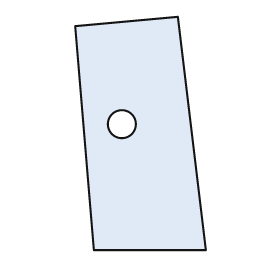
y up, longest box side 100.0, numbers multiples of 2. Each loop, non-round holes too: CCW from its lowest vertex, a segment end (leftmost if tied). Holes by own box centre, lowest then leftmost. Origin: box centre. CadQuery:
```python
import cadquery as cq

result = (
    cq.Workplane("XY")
    .moveTo(-20.0, -50.0)
    .lineTo(28.0, -50.0)
    .lineTo(16.0, 50.0)
    .lineTo(-28.0, 46.0)
    .close()
    .moveTo(-8.0, 4.0)
    .circle(6.0)
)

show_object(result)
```